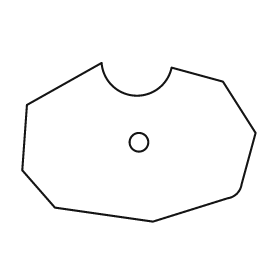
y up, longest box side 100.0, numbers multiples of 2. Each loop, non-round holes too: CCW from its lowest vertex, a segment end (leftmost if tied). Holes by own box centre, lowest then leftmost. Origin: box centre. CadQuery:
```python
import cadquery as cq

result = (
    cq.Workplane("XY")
    .moveTo(6.0, -34.0)
    .lineTo(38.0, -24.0)
    .threePointArc((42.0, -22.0), (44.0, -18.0))
    .lineTo(50.0, 4.0)
    .lineTo(36.0, 26.0)
    .lineTo(14.0, 32.0)
    .threePointArc((-2.0, 20.0), (-16.0, 34.0))
    .lineTo(-48.0, 16.0)
    .lineTo(-50.0, -12.0)
    .lineTo(-36.0, -28.0)
    .close()
    .moveTo(0.0, 0.0)
    .circle(4.0)
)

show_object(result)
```